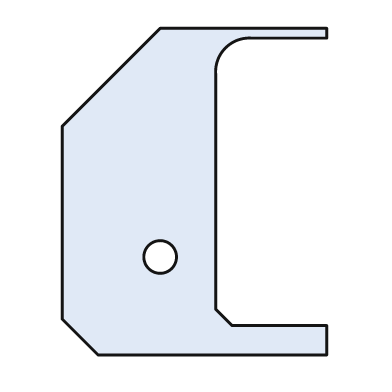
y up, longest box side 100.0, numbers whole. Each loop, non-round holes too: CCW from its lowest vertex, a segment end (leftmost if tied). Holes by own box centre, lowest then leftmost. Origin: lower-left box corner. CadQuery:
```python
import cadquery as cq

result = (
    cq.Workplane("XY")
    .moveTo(11.0, 0.0)
    .lineTo(81.0, 0.0)
    .lineTo(81.0, 9.0)
    .lineTo(52.0, 9.0)
    .lineTo(47.0, 14.0)
    .lineTo(47.0, 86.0)
    .threePointArc((50.0, 94.0), (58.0, 97.0))
    .lineTo(81.0, 97.0)
    .lineTo(81.0, 100.0)
    .lineTo(30.0, 100.0)
    .lineTo(0.0, 70.0)
    .lineTo(0.0, 11.0)
    .close()
    .moveTo(30.0, 30.0)
    .circle(5.0)
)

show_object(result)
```